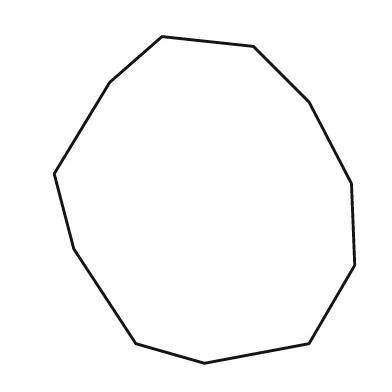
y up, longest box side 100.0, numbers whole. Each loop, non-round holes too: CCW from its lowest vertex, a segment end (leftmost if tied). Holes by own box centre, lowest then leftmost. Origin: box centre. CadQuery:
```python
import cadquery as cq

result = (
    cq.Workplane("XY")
    .moveTo(0.0, -50.0)
    .lineTo(32.0, -44.0)
    .lineTo(46.0, -20.0)
    .lineTo(45.0, 5.0)
    .lineTo(32.0, 30.0)
    .lineTo(15.0, 47.0)
    .lineTo(-13.0, 50.0)
    .lineTo(-29.0, 36.0)
    .lineTo(-46.0, 8.0)
    .lineTo(-40.0, -15.0)
    .lineTo(-21.0, -44.0)
    .close()
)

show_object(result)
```